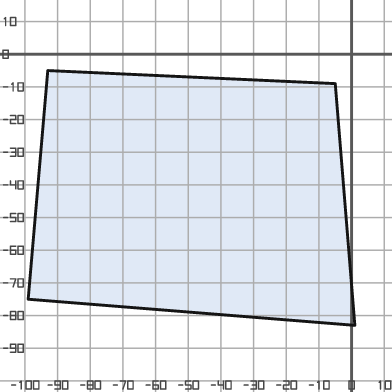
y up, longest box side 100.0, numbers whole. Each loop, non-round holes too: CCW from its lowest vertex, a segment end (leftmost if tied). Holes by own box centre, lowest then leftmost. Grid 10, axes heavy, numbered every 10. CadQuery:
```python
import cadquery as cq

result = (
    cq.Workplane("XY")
    .moveTo(1.0, -83.0)
    .lineTo(-5.0, -9.0)
    .lineTo(-93.0, -5.0)
    .lineTo(-99.0, -75.0)
    .close()
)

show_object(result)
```